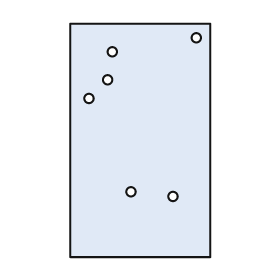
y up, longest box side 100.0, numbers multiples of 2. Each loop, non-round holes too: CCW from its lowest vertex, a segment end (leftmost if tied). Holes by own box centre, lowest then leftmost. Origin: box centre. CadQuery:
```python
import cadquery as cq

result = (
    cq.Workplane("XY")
    .moveTo(-30.0, -50.0)
    .lineTo(30.0, -50.0)
    .lineTo(30.0, 50.0)
    .lineTo(-30.0, 50.0)
    .close()
    .moveTo(14.0, -24.0)
    .circle(2.0)
    .moveTo(-4.0, -22.0)
    .circle(2.0)
    .moveTo(-22.0, 18.0)
    .circle(2.0)
    .moveTo(-14.0, 26.0)
    .circle(2.0)
    .moveTo(-12.0, 38.0)
    .circle(2.0)
    .moveTo(24.0, 44.0)
    .circle(2.0)
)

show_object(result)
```